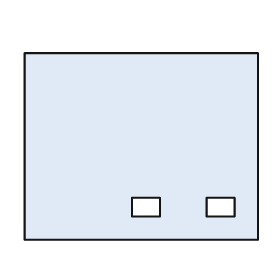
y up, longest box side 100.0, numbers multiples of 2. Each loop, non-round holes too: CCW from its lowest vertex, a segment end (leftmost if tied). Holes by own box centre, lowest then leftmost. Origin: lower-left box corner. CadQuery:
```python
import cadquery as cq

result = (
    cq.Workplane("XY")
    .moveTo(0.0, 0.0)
    .lineTo(100.0, 0.0)
    .lineTo(100.0, 80.0)
    .lineTo(0.0, 80.0)
    .close()
    .moveTo(46.0, 10.0)
    .lineTo(58.0, 10.0)
    .lineTo(58.0, 18.0)
    .lineTo(46.0, 18.0)
    .close()
    .moveTo(78.0, 10.0)
    .lineTo(90.0, 10.0)
    .lineTo(90.0, 18.0)
    .lineTo(78.0, 18.0)
    .close()
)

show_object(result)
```